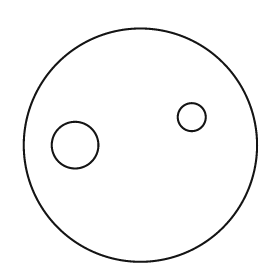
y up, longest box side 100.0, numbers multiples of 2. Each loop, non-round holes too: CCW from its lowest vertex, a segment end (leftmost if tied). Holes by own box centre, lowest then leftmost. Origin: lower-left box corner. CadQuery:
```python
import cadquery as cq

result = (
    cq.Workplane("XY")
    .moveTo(50.0, 50.0)
    .circle(50.0)
    .moveTo(22.0, 50.0)
    .circle(10.0)
    .moveTo(72.0, 62.0)
    .circle(6.0)
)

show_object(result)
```